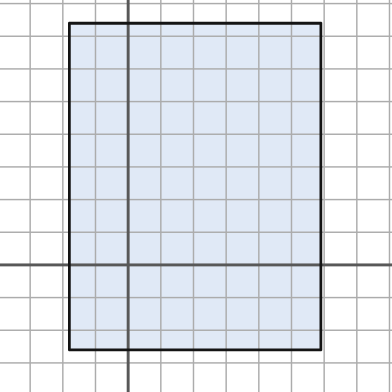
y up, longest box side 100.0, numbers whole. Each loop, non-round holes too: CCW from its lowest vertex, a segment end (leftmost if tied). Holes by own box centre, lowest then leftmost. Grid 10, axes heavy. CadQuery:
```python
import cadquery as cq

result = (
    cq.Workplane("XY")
    .moveTo(-18.0, -26.0)
    .lineTo(59.0, -26.0)
    .lineTo(59.0, 74.0)
    .lineTo(-18.0, 74.0)
    .close()
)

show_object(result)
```